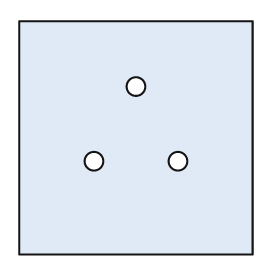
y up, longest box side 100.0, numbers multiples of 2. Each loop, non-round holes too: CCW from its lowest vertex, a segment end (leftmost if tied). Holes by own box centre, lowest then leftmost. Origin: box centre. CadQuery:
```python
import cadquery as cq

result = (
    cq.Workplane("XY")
    .moveTo(-50.0, -50.0)
    .lineTo(50.0, -50.0)
    .lineTo(50.0, 50.0)
    .lineTo(-50.0, 50.0)
    .close()
    .moveTo(-18.0, -10.0)
    .circle(4.0)
    .moveTo(18.0, -10.0)
    .circle(4.0)
    .moveTo(0.0, 22.0)
    .circle(4.0)
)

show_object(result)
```